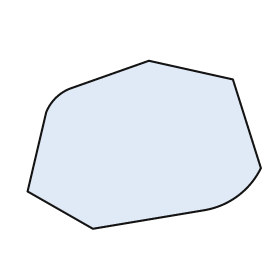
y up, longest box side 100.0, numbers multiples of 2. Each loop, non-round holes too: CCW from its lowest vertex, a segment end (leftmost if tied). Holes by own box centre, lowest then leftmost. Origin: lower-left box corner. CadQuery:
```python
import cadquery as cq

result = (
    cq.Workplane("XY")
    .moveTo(28.0, 0.0)
    .lineTo(76.0, 8.0)
    .threePointArc((90.0, 14.0), (100.0, 26.0))
    .lineTo(88.0, 64.0)
    .lineTo(52.0, 72.0)
    .lineTo(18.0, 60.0)
    .threePointArc((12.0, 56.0), (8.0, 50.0))
    .lineTo(0.0, 16.0)
    .close()
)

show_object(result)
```